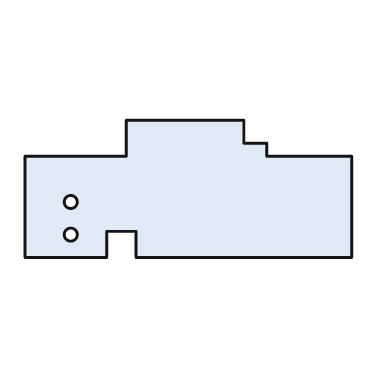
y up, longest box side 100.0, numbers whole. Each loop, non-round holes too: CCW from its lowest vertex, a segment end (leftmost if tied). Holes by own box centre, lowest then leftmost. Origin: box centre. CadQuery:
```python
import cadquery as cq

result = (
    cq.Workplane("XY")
    .moveTo(-50.0, -21.0)
    .lineTo(-25.0, -21.0)
    .lineTo(-25.0, -13.0)
    .lineTo(-16.0, -13.0)
    .lineTo(-16.0, -21.0)
    .lineTo(50.0, -21.0)
    .lineTo(50.0, 10.0)
    .lineTo(24.0, 10.0)
    .lineTo(24.0, 14.0)
    .lineTo(17.0, 14.0)
    .lineTo(17.0, 21.0)
    .lineTo(-19.0, 21.0)
    .lineTo(-19.0, 10.0)
    .lineTo(-50.0, 10.0)
    .close()
    .moveTo(-36.0, -14.0)
    .circle(2.0)
    .moveTo(-36.0, -4.0)
    .circle(2.0)
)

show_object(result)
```